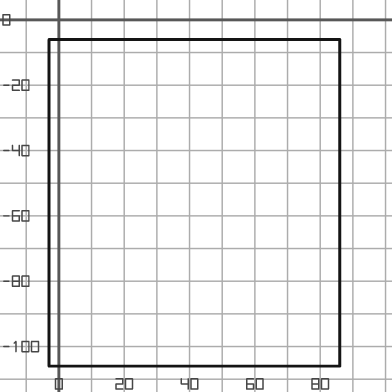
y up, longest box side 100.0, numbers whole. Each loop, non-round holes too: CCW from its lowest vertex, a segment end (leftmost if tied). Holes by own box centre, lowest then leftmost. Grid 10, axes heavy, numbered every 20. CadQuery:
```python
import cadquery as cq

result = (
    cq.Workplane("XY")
    .moveTo(-3.0, -106.0)
    .lineTo(86.0, -106.0)
    .lineTo(86.0, -6.0)
    .lineTo(-3.0, -6.0)
    .close()
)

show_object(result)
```